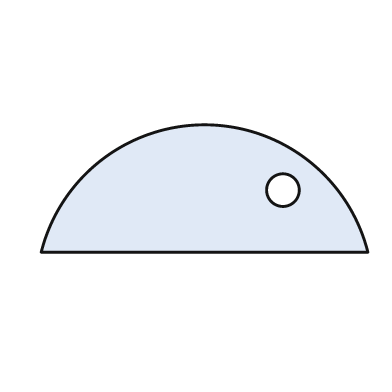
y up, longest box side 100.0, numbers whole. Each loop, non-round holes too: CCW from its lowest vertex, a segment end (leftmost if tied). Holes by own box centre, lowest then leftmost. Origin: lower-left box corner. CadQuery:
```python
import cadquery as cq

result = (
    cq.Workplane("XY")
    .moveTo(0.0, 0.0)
    .lineTo(100.0, 0.0)
    .threePointArc((50.0, 39.0), (0.0, 0.0))
    .close()
    .moveTo(74.0, 19.0)
    .circle(5.0)
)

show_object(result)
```